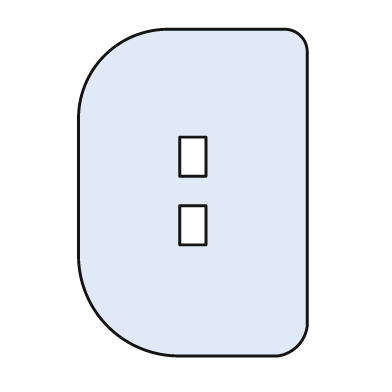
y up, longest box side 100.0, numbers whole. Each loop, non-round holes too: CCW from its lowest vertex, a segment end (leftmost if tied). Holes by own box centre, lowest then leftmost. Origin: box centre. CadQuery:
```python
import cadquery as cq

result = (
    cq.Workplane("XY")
    .moveTo(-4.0, -50.0)
    .lineTo(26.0, -50.0)
    .threePointArc((32.0, -47.0), (35.0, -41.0))
    .lineTo(35.0, 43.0)
    .threePointArc((33.0, 48.0), (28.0, 50.0))
    .lineTo(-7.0, 50.0)
    .threePointArc((-27.0, 42.0), (-35.0, 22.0))
    .lineTo(-35.0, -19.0)
    .threePointArc((-26.0, -41.0), (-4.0, -50.0))
    .close()
    .moveTo(-4.0, -16.0)
    .lineTo(4.0, -16.0)
    .lineTo(4.0, -4.0)
    .lineTo(-4.0, -4.0)
    .close()
    .moveTo(-4.0, 5.0)
    .lineTo(4.0, 5.0)
    .lineTo(4.0, 17.0)
    .lineTo(-4.0, 17.0)
    .close()
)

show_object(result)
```